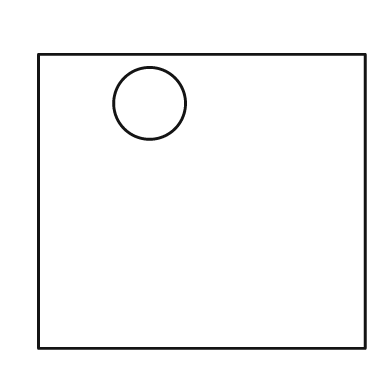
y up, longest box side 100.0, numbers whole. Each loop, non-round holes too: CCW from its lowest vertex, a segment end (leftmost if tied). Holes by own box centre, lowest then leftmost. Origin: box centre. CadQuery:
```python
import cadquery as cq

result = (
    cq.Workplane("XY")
    .moveTo(-50.0, -45.0)
    .lineTo(50.0, -45.0)
    .lineTo(50.0, 45.0)
    .lineTo(-50.0, 45.0)
    .close()
    .moveTo(-16.0, 30.0)
    .circle(11.0)
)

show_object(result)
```